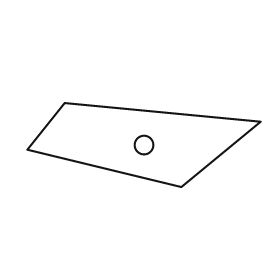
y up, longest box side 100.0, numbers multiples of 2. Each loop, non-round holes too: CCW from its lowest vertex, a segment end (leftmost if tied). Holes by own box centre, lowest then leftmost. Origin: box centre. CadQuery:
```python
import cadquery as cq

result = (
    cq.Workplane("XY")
    .moveTo(16.0, -18.0)
    .lineTo(50.0, 10.0)
    .lineTo(-34.0, 18.0)
    .lineTo(-50.0, -2.0)
    .close()
    .moveTo(0.0, 0.0)
    .circle(4.0)
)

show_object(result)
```